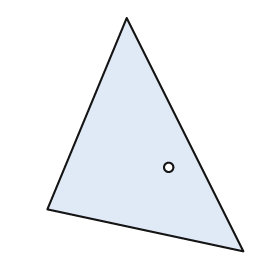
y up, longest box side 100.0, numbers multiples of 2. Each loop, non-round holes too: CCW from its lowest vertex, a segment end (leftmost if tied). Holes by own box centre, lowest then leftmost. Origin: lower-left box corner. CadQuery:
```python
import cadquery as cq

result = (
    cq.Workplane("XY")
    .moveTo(84.0, 0.0)
    .lineTo(34.0, 100.0)
    .lineTo(0.0, 18.0)
    .close()
    .moveTo(52.0, 36.0)
    .circle(2.0)
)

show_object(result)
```